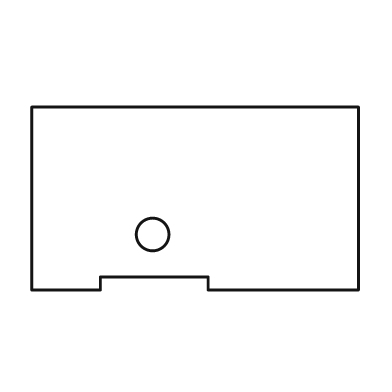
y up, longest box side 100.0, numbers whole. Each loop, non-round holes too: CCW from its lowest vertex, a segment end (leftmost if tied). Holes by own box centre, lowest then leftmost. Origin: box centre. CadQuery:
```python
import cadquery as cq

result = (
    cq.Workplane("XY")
    .moveTo(-50.0, -28.0)
    .lineTo(-29.0, -28.0)
    .lineTo(-29.0, -24.0)
    .lineTo(4.0, -24.0)
    .lineTo(4.0, -28.0)
    .lineTo(50.0, -28.0)
    .lineTo(50.0, 28.0)
    .lineTo(-50.0, 28.0)
    .close()
    .moveTo(-13.0, -11.0)
    .circle(5.0)
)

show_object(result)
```